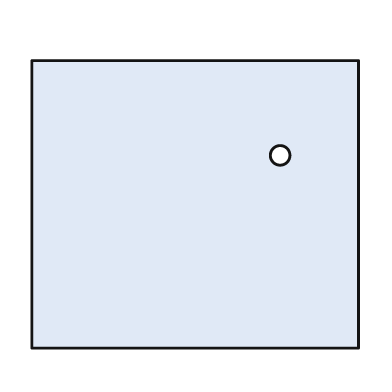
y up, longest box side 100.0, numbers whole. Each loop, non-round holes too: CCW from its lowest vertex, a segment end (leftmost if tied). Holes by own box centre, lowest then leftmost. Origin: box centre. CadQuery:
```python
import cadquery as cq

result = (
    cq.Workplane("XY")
    .moveTo(-50.0, -44.0)
    .lineTo(50.0, -44.0)
    .lineTo(50.0, 44.0)
    .lineTo(-50.0, 44.0)
    .close()
    .moveTo(26.0, 15.0)
    .circle(3.0)
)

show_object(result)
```